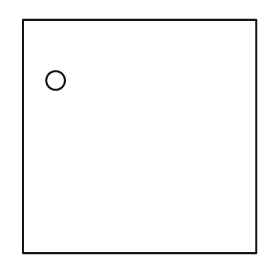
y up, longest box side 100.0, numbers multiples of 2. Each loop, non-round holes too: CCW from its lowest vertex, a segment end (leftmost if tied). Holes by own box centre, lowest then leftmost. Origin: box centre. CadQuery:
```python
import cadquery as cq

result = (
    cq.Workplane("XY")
    .moveTo(-50.0, -50.0)
    .lineTo(50.0, -50.0)
    .lineTo(50.0, 50.0)
    .lineTo(-50.0, 50.0)
    .close()
    .moveTo(-36.0, 24.0)
    .circle(4.0)
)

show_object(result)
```